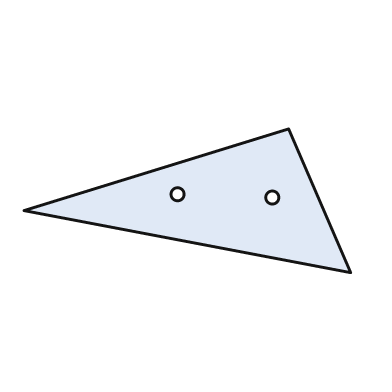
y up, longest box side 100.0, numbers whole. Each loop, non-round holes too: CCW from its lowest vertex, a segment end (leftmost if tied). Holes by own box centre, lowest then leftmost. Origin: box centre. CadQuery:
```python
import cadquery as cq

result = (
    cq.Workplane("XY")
    .moveTo(50.0, -22.0)
    .lineTo(31.0, 22.0)
    .lineTo(-50.0, -3.0)
    .close()
    .moveTo(26.0, 1.0)
    .circle(2.0)
    .moveTo(-3.0, 2.0)
    .circle(2.0)
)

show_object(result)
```